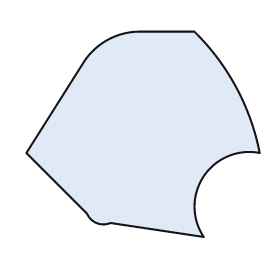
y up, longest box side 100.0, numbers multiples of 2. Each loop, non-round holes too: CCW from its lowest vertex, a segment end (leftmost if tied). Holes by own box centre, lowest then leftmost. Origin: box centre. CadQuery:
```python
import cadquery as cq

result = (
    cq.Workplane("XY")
    .moveTo(26.0, -44.0)
    .threePointArc((26.0, -18.0), (50.0, -8.0))
    .threePointArc((40.0, 20.0), (22.0, 44.0))
    .lineTo(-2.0, 44.0)
    .threePointArc((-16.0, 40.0), (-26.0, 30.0))
    .lineTo(-50.0, -8.0)
    .lineTo(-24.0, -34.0)
    .threePointArc((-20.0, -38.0), (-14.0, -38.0))
    .close()
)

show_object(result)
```